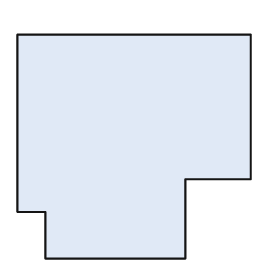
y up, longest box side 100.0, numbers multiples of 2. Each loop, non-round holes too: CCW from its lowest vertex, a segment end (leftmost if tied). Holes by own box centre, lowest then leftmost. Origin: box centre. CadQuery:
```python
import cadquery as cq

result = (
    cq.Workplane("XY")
    .moveTo(-38.0, -48.0)
    .lineTo(22.0, -48.0)
    .lineTo(22.0, -14.0)
    .lineTo(50.0, -14.0)
    .lineTo(50.0, 48.0)
    .lineTo(-50.0, 48.0)
    .lineTo(-50.0, -28.0)
    .lineTo(-38.0, -28.0)
    .close()
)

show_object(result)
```